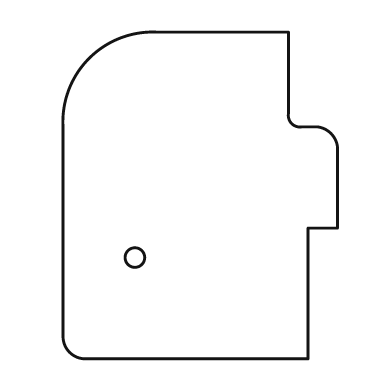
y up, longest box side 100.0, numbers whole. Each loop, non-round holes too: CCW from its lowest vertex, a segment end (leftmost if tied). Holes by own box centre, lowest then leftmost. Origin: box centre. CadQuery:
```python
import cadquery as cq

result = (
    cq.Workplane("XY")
    .moveTo(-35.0, -50.0)
    .lineTo(33.0, -50.0)
    .lineTo(33.0, -10.0)
    .lineTo(42.0, -10.0)
    .lineTo(42.0, 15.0)
    .threePointArc((40.0, 19.0), (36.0, 21.0))
    .lineTo(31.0, 21.0)
    .threePointArc((28.0, 22.0), (27.0, 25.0))
    .lineTo(27.0, 50.0)
    .lineTo(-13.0, 50.0)
    .threePointArc((-34.0, 42.0), (-42.0, 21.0))
    .lineTo(-42.0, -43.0)
    .threePointArc((-40.0, -48.0), (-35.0, -50.0))
    .close()
    .moveTo(-20.0, -19.0)
    .circle(3.0)
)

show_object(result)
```